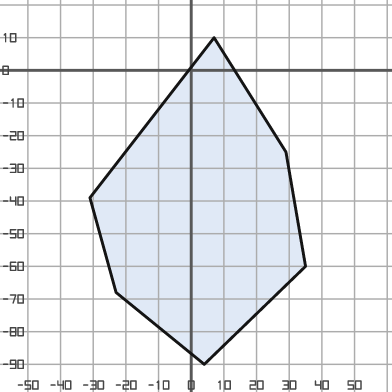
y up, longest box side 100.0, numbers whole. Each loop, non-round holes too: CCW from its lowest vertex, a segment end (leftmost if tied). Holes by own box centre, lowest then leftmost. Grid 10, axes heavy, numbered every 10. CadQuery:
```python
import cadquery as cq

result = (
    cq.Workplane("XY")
    .moveTo(4.0, -90.0)
    .lineTo(35.0, -60.0)
    .lineTo(29.0, -25.0)
    .lineTo(7.0, 10.0)
    .lineTo(-31.0, -39.0)
    .lineTo(-23.0, -68.0)
    .close()
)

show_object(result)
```